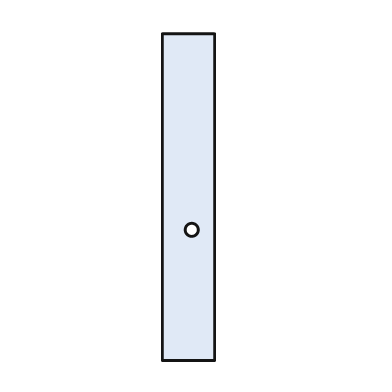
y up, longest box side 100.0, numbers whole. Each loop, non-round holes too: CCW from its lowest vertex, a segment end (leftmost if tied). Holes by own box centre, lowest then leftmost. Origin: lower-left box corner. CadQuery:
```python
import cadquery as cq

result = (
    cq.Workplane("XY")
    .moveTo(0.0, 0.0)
    .lineTo(16.0, 0.0)
    .lineTo(16.0, 100.0)
    .lineTo(0.0, 100.0)
    .close()
    .moveTo(9.0, 40.0)
    .circle(2.0)
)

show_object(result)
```